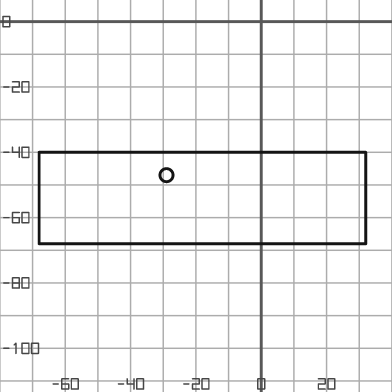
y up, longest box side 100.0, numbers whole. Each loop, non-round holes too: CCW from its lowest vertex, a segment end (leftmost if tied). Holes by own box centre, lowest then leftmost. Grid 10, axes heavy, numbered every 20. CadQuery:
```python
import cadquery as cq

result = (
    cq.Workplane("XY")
    .moveTo(-68.0, -68.0)
    .lineTo(32.0, -68.0)
    .lineTo(32.0, -40.0)
    .lineTo(-68.0, -40.0)
    .close()
    .moveTo(-29.0, -47.0)
    .circle(2.0)
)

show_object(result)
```